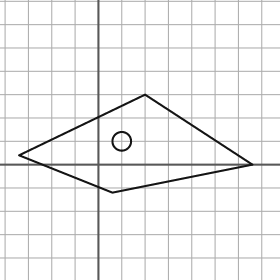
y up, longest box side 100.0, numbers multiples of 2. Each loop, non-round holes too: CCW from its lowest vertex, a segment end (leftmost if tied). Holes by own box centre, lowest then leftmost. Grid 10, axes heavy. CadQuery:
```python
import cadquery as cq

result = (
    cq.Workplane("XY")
    .moveTo(6.0, -12.0)
    .lineTo(66.0, 0.0)
    .lineTo(20.0, 30.0)
    .lineTo(-34.0, 4.0)
    .close()
    .moveTo(10.0, 10.0)
    .circle(4.0)
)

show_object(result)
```